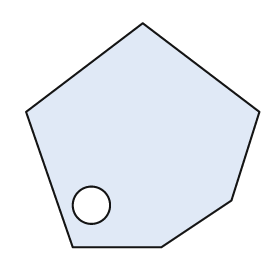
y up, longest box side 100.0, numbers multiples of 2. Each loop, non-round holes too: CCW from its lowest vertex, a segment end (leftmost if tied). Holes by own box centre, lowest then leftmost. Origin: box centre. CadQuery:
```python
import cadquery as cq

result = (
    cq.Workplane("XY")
    .moveTo(-30.0, -48.0)
    .lineTo(8.0, -48.0)
    .lineTo(38.0, -28.0)
    .lineTo(50.0, 10.0)
    .lineTo(0.0, 48.0)
    .lineTo(-50.0, 10.0)
    .close()
    .moveTo(-22.0, -30.0)
    .circle(8.0)
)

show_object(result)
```